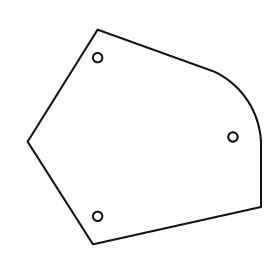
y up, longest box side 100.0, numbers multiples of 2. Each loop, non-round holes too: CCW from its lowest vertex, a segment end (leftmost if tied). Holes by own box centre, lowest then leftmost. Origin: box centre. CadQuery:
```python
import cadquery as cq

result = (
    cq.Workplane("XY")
    .moveTo(-22.0, -46.0)
    .lineTo(50.0, -30.0)
    .lineTo(50.0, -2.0)
    .threePointArc((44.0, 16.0), (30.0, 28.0))
    .lineTo(-20.0, 46.0)
    .lineTo(-50.0, -2.0)
    .close()
    .moveTo(-20.0, -34.0)
    .circle(2.0)
    .moveTo(38.0, 0.0)
    .circle(2.0)
    .moveTo(-20.0, 34.0)
    .circle(2.0)
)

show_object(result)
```